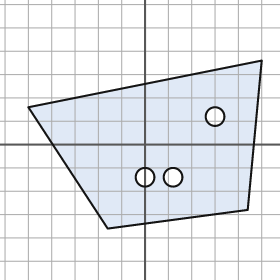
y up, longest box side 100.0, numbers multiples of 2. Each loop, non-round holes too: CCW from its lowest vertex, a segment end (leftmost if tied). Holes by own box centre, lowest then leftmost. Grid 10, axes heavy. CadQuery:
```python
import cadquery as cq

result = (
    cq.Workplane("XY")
    .moveTo(-16.0, -36.0)
    .lineTo(44.0, -28.0)
    .lineTo(50.0, 36.0)
    .lineTo(-50.0, 16.0)
    .close()
    .moveTo(0.0, -14.0)
    .circle(4.0)
    .moveTo(12.0, -14.0)
    .circle(4.0)
    .moveTo(30.0, 12.0)
    .circle(4.0)
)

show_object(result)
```